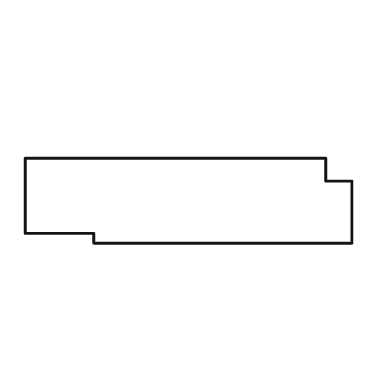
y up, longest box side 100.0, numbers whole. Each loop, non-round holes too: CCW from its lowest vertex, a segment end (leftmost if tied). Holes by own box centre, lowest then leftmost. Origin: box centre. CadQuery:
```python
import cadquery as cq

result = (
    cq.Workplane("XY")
    .moveTo(-29.0, -13.0)
    .lineTo(50.0, -13.0)
    .lineTo(50.0, 6.0)
    .lineTo(42.0, 6.0)
    .lineTo(42.0, 13.0)
    .lineTo(-50.0, 13.0)
    .lineTo(-50.0, -10.0)
    .lineTo(-29.0, -10.0)
    .close()
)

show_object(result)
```